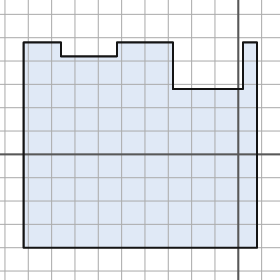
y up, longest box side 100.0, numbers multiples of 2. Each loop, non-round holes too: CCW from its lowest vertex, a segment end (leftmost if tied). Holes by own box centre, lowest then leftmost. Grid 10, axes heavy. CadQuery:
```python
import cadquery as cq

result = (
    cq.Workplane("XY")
    .moveTo(-92.0, -40.0)
    .lineTo(8.0, -40.0)
    .lineTo(8.0, 48.0)
    .lineTo(2.0, 48.0)
    .lineTo(2.0, 28.0)
    .lineTo(-28.0, 28.0)
    .lineTo(-28.0, 48.0)
    .lineTo(-52.0, 48.0)
    .lineTo(-52.0, 42.0)
    .lineTo(-76.0, 42.0)
    .lineTo(-76.0, 48.0)
    .lineTo(-92.0, 48.0)
    .close()
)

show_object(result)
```